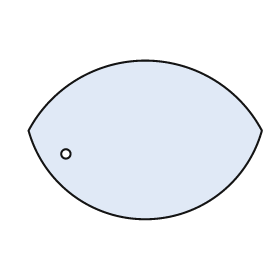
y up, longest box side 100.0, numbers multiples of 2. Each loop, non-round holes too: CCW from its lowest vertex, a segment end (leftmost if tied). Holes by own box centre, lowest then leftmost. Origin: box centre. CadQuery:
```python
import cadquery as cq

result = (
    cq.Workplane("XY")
    .moveTo(-50.0, 4.0)
    .threePointArc((0.0, -34.0), (50.0, 4.0))
    .threePointArc((0.0, 34.0), (-50.0, 4.0))
    .close()
    .moveTo(-34.0, -6.0)
    .circle(2.0)
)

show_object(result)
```